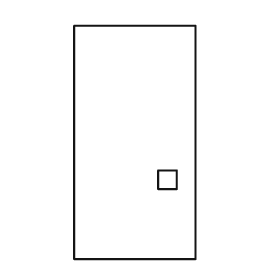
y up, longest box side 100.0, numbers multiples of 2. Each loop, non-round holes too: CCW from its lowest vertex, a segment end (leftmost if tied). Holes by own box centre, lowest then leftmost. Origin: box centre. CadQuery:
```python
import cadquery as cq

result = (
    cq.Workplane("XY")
    .moveTo(-26.0, -50.0)
    .lineTo(26.0, -50.0)
    .lineTo(26.0, 50.0)
    .lineTo(-26.0, 50.0)
    .close()
    .moveTo(10.0, -20.0)
    .lineTo(18.0, -20.0)
    .lineTo(18.0, -12.0)
    .lineTo(10.0, -12.0)
    .close()
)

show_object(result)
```